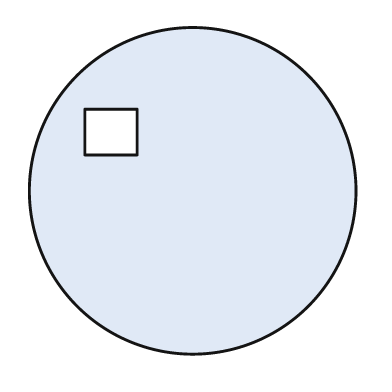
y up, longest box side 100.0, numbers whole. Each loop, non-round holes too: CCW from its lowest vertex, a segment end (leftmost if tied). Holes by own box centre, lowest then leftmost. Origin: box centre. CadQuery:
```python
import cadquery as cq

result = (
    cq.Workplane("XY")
    .moveTo(0.0, 0.0)
    .circle(50.0)
    .moveTo(-33.0, 11.0)
    .lineTo(-17.0, 11.0)
    .lineTo(-17.0, 25.0)
    .lineTo(-33.0, 25.0)
    .close()
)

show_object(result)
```